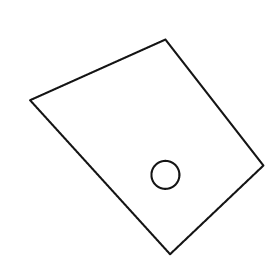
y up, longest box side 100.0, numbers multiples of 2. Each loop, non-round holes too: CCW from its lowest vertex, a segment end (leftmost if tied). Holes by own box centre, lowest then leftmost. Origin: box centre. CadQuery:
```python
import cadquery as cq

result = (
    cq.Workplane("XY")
    .moveTo(10.0, -46.0)
    .lineTo(50.0, -8.0)
    .lineTo(8.0, 46.0)
    .lineTo(-50.0, 20.0)
    .close()
    .moveTo(8.0, -12.0)
    .circle(6.0)
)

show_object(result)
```